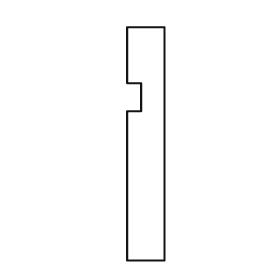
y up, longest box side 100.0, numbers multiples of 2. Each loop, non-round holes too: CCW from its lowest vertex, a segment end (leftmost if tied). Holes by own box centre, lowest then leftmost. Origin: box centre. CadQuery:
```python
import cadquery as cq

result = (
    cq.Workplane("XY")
    .moveTo(-8.0, -50.0)
    .lineTo(8.0, -50.0)
    .lineTo(8.0, 50.0)
    .lineTo(-8.0, 50.0)
    .lineTo(-8.0, 26.0)
    .lineTo(-2.0, 26.0)
    .lineTo(-2.0, 14.0)
    .lineTo(-8.0, 14.0)
    .close()
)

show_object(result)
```